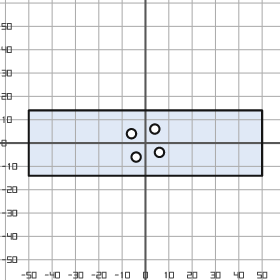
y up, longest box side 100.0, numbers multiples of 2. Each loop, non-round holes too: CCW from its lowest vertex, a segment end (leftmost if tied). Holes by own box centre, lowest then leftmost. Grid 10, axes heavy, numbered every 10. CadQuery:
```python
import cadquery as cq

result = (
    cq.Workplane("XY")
    .moveTo(-50.0, -14.0)
    .lineTo(50.0, -14.0)
    .lineTo(50.0, 14.0)
    .lineTo(-50.0, 14.0)
    .close()
    .moveTo(-4.0, -6.0)
    .circle(2.0)
    .moveTo(6.0, -4.0)
    .circle(2.0)
    .moveTo(-6.0, 4.0)
    .circle(2.0)
    .moveTo(4.0, 6.0)
    .circle(2.0)
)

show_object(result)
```